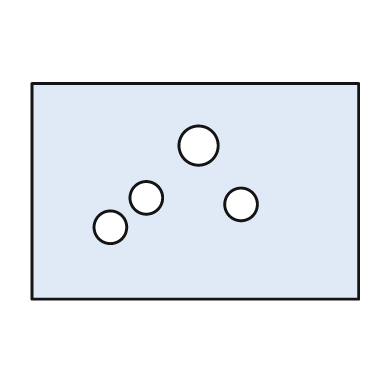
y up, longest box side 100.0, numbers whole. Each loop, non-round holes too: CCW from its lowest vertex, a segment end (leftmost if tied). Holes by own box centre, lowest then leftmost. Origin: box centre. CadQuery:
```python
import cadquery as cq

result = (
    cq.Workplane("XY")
    .moveTo(-50.0, -33.0)
    .lineTo(50.0, -33.0)
    .lineTo(50.0, 33.0)
    .lineTo(-50.0, 33.0)
    .close()
    .moveTo(-26.0, -11.0)
    .circle(5.0)
    .moveTo(14.0, -4.0)
    .circle(5.0)
    .moveTo(-15.0, -2.0)
    .circle(5.0)
    .moveTo(1.0, 14.0)
    .circle(6.0)
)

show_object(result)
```